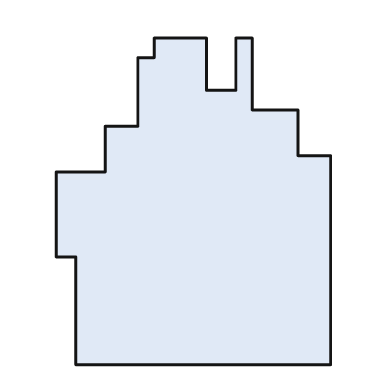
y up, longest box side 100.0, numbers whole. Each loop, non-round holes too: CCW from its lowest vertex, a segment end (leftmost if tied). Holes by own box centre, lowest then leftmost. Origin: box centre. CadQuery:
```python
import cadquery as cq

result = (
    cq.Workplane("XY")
    .moveTo(-36.0, -50.0)
    .lineTo(42.0, -50.0)
    .lineTo(42.0, 14.0)
    .lineTo(32.0, 14.0)
    .lineTo(32.0, 28.0)
    .lineTo(18.0, 28.0)
    .lineTo(18.0, 50.0)
    .lineTo(13.0, 50.0)
    .lineTo(13.0, 34.0)
    .lineTo(4.0, 34.0)
    .lineTo(4.0, 50.0)
    .lineTo(-12.0, 50.0)
    .lineTo(-12.0, 44.0)
    .lineTo(-17.0, 44.0)
    .lineTo(-17.0, 23.0)
    .lineTo(-27.0, 23.0)
    .lineTo(-27.0, 9.0)
    .lineTo(-42.0, 9.0)
    .lineTo(-42.0, -17.0)
    .lineTo(-36.0, -17.0)
    .close()
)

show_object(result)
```